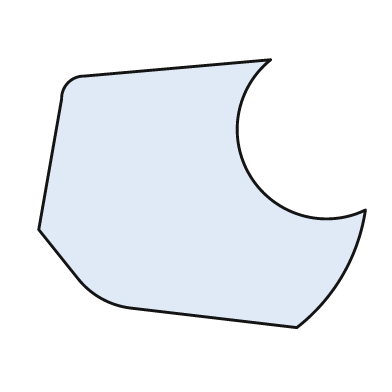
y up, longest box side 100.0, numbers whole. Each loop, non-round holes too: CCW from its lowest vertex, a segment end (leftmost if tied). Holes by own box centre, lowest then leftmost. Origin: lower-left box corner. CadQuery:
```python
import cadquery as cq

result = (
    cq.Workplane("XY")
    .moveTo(79.0, 0.0)
    .threePointArc((93.0, 16.0), (100.0, 36.0))
    .threePointArc((65.0, 46.0), (71.0, 82.0))
    .lineTo(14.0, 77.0)
    .threePointArc((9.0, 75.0), (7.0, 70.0))
    .lineTo(0.0, 30.0)
    .lineTo(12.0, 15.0)
    .threePointArc((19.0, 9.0), (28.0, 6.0))
    .close()
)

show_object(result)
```